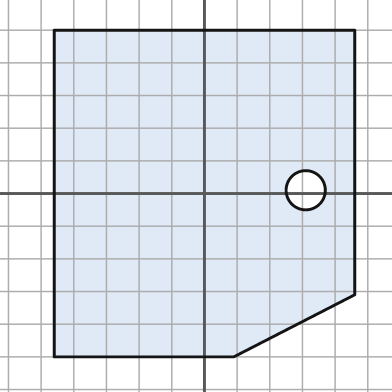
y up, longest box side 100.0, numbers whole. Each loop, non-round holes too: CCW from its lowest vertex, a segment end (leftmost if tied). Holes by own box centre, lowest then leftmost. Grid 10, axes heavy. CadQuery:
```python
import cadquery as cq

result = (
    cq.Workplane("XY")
    .moveTo(-46.0, -50.0)
    .lineTo(9.0, -50.0)
    .lineTo(46.0, -31.0)
    .lineTo(46.0, 50.0)
    .lineTo(-46.0, 50.0)
    .close()
    .moveTo(31.0, 1.0)
    .circle(6.0)
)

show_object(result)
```